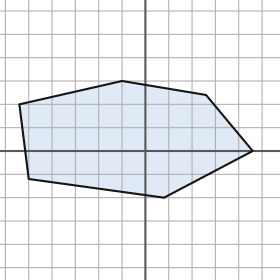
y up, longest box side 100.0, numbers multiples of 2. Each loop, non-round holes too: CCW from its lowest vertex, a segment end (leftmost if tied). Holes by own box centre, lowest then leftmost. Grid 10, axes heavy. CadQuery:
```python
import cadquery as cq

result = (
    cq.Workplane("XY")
    .moveTo(8.0, -20.0)
    .lineTo(46.0, 0.0)
    .lineTo(26.0, 24.0)
    .lineTo(-10.0, 30.0)
    .lineTo(-54.0, 20.0)
    .lineTo(-50.0, -12.0)
    .close()
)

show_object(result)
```